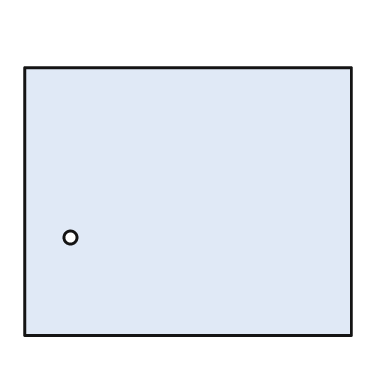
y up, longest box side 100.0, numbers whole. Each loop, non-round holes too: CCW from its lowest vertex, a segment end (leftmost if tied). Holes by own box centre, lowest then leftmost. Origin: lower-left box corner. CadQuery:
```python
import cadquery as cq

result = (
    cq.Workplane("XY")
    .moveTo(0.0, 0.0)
    .lineTo(100.0, 0.0)
    .lineTo(100.0, 82.0)
    .lineTo(0.0, 82.0)
    .close()
    .moveTo(14.0, 30.0)
    .circle(2.0)
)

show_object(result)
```